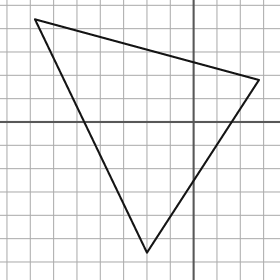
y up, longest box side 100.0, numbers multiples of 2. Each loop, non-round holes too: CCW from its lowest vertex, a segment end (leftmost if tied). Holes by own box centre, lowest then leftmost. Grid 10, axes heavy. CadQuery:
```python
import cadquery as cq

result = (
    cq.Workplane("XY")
    .moveTo(-20.0, -56.0)
    .lineTo(28.0, 18.0)
    .lineTo(-68.0, 44.0)
    .close()
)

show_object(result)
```